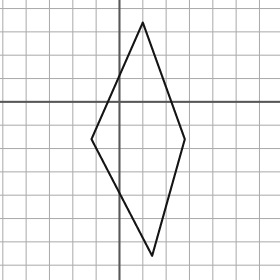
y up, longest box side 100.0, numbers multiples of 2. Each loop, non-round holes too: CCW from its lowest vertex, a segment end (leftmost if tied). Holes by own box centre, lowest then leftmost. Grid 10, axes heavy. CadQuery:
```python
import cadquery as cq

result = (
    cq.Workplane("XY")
    .moveTo(14.0, -66.0)
    .lineTo(28.0, -16.0)
    .lineTo(10.0, 34.0)
    .lineTo(-12.0, -16.0)
    .close()
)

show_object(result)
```